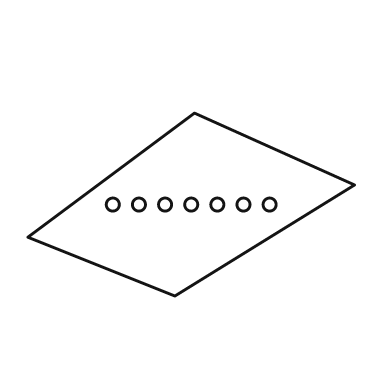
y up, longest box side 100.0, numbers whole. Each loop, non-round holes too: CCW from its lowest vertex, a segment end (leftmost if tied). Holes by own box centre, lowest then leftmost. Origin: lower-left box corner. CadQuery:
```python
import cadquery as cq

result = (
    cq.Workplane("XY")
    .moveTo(45.0, 0.0)
    .lineTo(100.0, 34.0)
    .lineTo(51.0, 56.0)
    .lineTo(0.0, 18.0)
    .close()
    .moveTo(26.0, 28.0)
    .circle(2.0)
    .moveTo(34.0, 28.0)
    .circle(2.0)
    .moveTo(42.0, 28.0)
    .circle(2.0)
    .moveTo(50.0, 28.0)
    .circle(2.0)
    .moveTo(58.0, 28.0)
    .circle(2.0)
    .moveTo(66.0, 28.0)
    .circle(2.0)
    .moveTo(74.0, 28.0)
    .circle(2.0)
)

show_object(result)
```